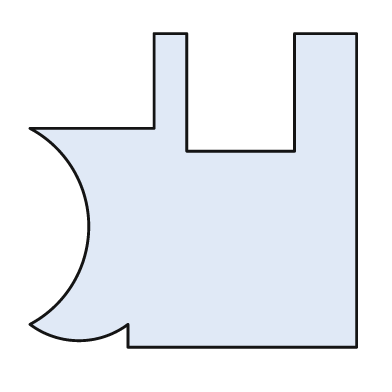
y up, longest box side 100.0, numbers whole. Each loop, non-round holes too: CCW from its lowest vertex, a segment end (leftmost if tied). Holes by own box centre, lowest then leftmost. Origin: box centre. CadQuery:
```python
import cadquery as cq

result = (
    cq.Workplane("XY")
    .moveTo(-20.0, -48.0)
    .lineTo(50.0, -48.0)
    .lineTo(50.0, 48.0)
    .lineTo(31.0, 48.0)
    .lineTo(31.0, 12.0)
    .lineTo(-2.0, 12.0)
    .lineTo(-2.0, 48.0)
    .lineTo(-12.0, 48.0)
    .lineTo(-12.0, 19.0)
    .lineTo(-50.0, 19.0)
    .threePointArc((-32.0, -11.0), (-50.0, -41.0))
    .threePointArc((-35.0, -46.0), (-20.0, -41.0))
    .close()
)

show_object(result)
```